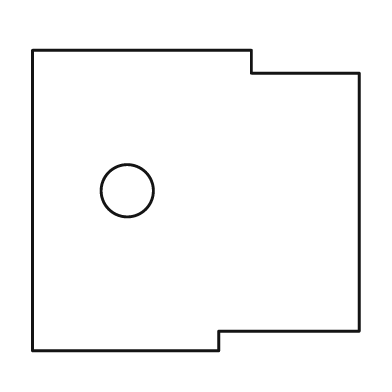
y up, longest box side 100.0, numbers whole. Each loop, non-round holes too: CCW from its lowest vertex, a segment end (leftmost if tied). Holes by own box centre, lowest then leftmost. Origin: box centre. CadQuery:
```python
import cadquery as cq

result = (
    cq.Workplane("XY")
    .moveTo(-50.0, -46.0)
    .lineTo(7.0, -46.0)
    .lineTo(7.0, -40.0)
    .lineTo(50.0, -40.0)
    .lineTo(50.0, 39.0)
    .lineTo(17.0, 39.0)
    .lineTo(17.0, 46.0)
    .lineTo(-50.0, 46.0)
    .close()
    .moveTo(-21.0, 3.0)
    .circle(8.0)
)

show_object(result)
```